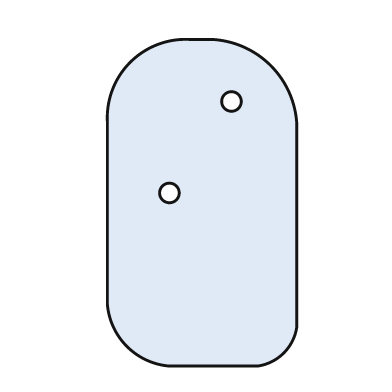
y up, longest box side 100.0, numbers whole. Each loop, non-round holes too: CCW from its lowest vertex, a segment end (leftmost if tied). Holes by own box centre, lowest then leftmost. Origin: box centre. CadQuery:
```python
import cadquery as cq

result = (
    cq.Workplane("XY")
    .moveTo(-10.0, -50.0)
    .lineTo(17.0, -50.0)
    .threePointArc((25.0, -46.0), (29.0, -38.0))
    .lineTo(29.0, 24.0)
    .threePointArc((21.0, 42.0), (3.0, 50.0))
    .lineTo(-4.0, 50.0)
    .threePointArc((-22.0, 43.0), (-29.0, 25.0))
    .lineTo(-29.0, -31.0)
    .threePointArc((-23.0, -44.0), (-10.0, -50.0))
    .close()
    .moveTo(-10.0, 3.0)
    .circle(3.0)
    .moveTo(9.0, 31.0)
    .circle(3.0)
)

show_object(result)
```